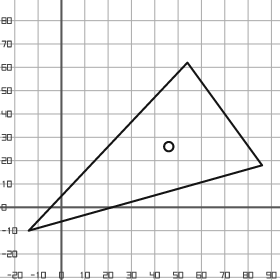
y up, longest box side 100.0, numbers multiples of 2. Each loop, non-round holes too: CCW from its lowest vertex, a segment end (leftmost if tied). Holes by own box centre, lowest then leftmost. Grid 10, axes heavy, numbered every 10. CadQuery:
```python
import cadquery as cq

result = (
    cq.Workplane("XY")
    .moveTo(-14.0, -10.0)
    .lineTo(86.0, 18.0)
    .lineTo(54.0, 62.0)
    .close()
    .moveTo(46.0, 26.0)
    .circle(2.0)
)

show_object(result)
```